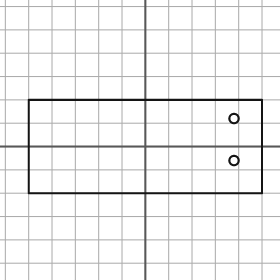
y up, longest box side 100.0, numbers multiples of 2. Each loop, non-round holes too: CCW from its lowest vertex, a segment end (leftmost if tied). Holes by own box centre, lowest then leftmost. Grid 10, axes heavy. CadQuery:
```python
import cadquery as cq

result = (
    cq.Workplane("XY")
    .moveTo(-50.0, -20.0)
    .lineTo(50.0, -20.0)
    .lineTo(50.0, 20.0)
    .lineTo(-50.0, 20.0)
    .close()
    .moveTo(38.0, -6.0)
    .circle(2.0)
    .moveTo(38.0, 12.0)
    .circle(2.0)
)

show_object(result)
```